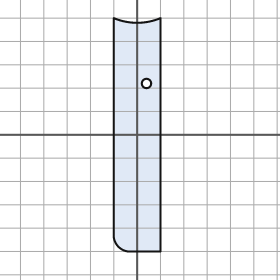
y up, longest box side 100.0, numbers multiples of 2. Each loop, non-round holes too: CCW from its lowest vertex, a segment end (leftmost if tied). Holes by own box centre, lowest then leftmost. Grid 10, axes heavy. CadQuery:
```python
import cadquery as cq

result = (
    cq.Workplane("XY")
    .moveTo(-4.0, -50.0)
    .lineTo(10.0, -50.0)
    .lineTo(10.0, 50.0)
    .threePointArc((0.0, 48.0), (-10.0, 50.0))
    .lineTo(-10.0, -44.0)
    .threePointArc((-8.0, -48.0), (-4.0, -50.0))
    .close()
    .moveTo(4.0, 22.0)
    .circle(2.0)
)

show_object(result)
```